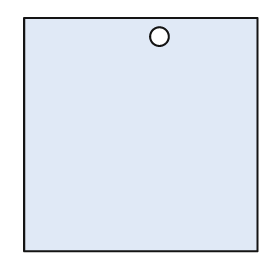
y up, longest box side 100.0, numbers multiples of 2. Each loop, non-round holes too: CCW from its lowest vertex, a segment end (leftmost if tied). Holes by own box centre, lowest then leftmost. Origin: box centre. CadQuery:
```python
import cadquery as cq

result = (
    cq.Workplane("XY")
    .moveTo(-50.0, -50.0)
    .lineTo(50.0, -50.0)
    .lineTo(50.0, 50.0)
    .lineTo(-50.0, 50.0)
    .close()
    .moveTo(8.0, 42.0)
    .circle(4.0)
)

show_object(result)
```